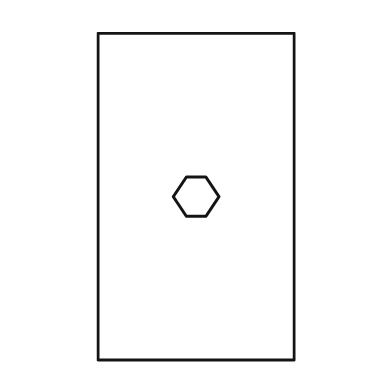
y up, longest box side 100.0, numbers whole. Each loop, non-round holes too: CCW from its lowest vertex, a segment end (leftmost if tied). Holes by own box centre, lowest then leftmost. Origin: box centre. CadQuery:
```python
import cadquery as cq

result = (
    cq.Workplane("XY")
    .moveTo(-30.0, -50.0)
    .lineTo(30.0, -50.0)
    .lineTo(30.0, 50.0)
    .lineTo(-30.0, 50.0)
    .close()
    .moveTo(-3.0, -6.0)
    .lineTo(3.0, -6.0)
    .lineTo(7.0, 0.0)
    .lineTo(3.0, 6.0)
    .lineTo(-3.0, 6.0)
    .lineTo(-7.0, 0.0)
    .close()
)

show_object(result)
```